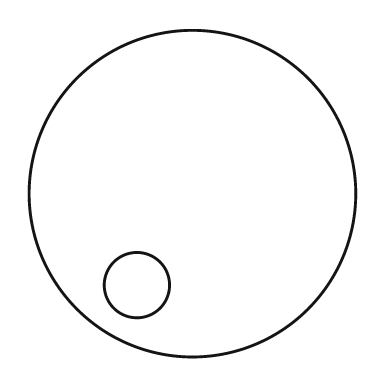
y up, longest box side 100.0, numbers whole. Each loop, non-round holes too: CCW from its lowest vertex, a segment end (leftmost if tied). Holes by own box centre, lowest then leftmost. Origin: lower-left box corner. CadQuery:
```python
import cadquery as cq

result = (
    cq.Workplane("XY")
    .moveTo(50.0, 50.0)
    .circle(50.0)
    .moveTo(33.0, 22.0)
    .circle(10.0)
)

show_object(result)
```